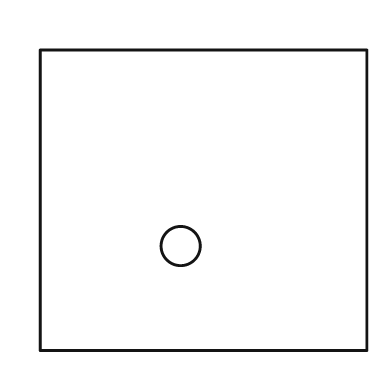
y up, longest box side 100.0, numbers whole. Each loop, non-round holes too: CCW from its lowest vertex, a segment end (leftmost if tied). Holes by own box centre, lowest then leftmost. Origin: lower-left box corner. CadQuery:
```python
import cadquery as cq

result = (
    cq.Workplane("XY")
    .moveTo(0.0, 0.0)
    .lineTo(100.0, 0.0)
    .lineTo(100.0, 92.0)
    .lineTo(0.0, 92.0)
    .close()
    .moveTo(43.0, 32.0)
    .circle(6.0)
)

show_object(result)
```